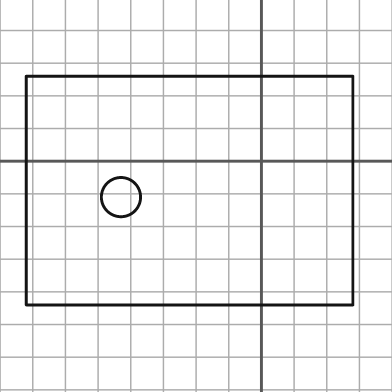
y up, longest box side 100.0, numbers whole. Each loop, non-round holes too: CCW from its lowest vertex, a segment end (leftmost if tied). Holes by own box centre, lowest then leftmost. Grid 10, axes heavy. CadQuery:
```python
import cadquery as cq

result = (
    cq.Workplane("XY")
    .moveTo(-72.0, -44.0)
    .lineTo(28.0, -44.0)
    .lineTo(28.0, 26.0)
    .lineTo(-72.0, 26.0)
    .close()
    .moveTo(-43.0, -11.0)
    .circle(6.0)
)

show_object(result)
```